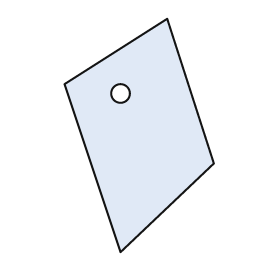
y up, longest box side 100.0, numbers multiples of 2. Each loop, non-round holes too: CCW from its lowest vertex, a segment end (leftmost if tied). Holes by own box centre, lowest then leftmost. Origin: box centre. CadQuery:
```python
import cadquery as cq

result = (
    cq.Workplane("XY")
    .moveTo(-8.0, -50.0)
    .lineTo(32.0, -12.0)
    .lineTo(12.0, 50.0)
    .lineTo(-32.0, 22.0)
    .close()
    .moveTo(-8.0, 18.0)
    .circle(4.0)
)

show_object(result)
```